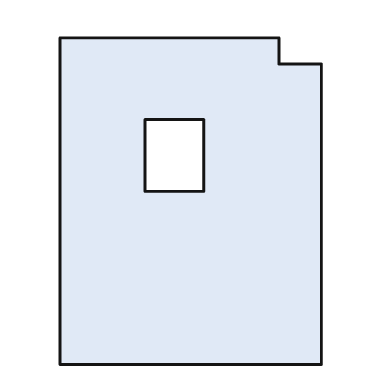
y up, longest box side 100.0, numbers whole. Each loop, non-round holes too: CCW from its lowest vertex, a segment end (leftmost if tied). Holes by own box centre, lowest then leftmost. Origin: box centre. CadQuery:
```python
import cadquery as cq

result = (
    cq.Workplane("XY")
    .moveTo(-40.0, -50.0)
    .lineTo(40.0, -50.0)
    .lineTo(40.0, 42.0)
    .lineTo(27.0, 42.0)
    .lineTo(27.0, 50.0)
    .lineTo(-40.0, 50.0)
    .close()
    .moveTo(-14.0, 3.0)
    .lineTo(4.0, 3.0)
    .lineTo(4.0, 25.0)
    .lineTo(-14.0, 25.0)
    .close()
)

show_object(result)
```